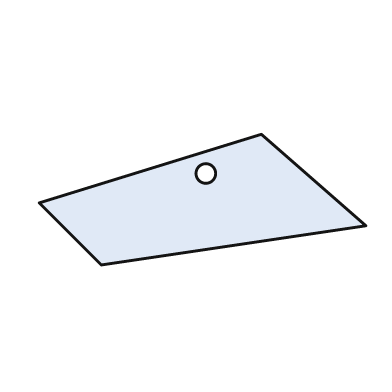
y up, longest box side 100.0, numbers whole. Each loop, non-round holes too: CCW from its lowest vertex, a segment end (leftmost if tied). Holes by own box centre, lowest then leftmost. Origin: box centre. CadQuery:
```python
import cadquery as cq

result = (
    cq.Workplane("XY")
    .moveTo(-31.0, -20.0)
    .lineTo(50.0, -8.0)
    .lineTo(18.0, 20.0)
    .lineTo(-50.0, -1.0)
    .close()
    .moveTo(1.0, 8.0)
    .circle(3.0)
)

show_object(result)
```